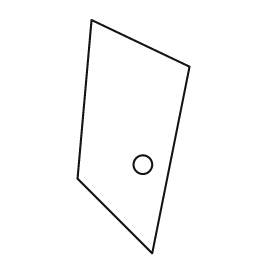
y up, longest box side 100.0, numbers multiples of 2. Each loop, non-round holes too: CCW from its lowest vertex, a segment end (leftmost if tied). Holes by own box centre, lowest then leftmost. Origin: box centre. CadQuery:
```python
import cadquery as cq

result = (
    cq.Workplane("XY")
    .moveTo(8.0, -50.0)
    .lineTo(24.0, 30.0)
    .lineTo(-18.0, 50.0)
    .lineTo(-24.0, -18.0)
    .close()
    .moveTo(4.0, -12.0)
    .circle(4.0)
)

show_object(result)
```